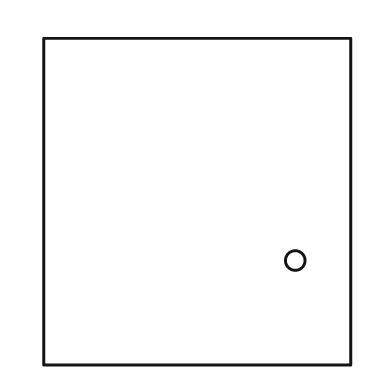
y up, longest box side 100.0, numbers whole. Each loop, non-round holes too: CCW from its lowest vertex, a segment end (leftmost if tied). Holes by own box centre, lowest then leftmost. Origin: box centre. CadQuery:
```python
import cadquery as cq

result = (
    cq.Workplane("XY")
    .moveTo(-47.0, -50.0)
    .lineTo(47.0, -50.0)
    .lineTo(47.0, 50.0)
    .lineTo(-47.0, 50.0)
    .close()
    .moveTo(30.0, -18.0)
    .circle(3.0)
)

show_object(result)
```